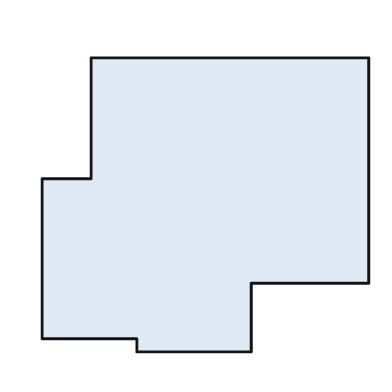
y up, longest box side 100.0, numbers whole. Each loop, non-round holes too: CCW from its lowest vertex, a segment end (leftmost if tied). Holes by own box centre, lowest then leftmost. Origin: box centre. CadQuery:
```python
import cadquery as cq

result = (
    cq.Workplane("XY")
    .moveTo(-21.0, -45.0)
    .lineTo(14.0, -45.0)
    .lineTo(14.0, -24.0)
    .lineTo(50.0, -24.0)
    .lineTo(50.0, 45.0)
    .lineTo(-35.0, 45.0)
    .lineTo(-35.0, 8.0)
    .lineTo(-50.0, 8.0)
    .lineTo(-50.0, -41.0)
    .lineTo(-21.0, -41.0)
    .close()
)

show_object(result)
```